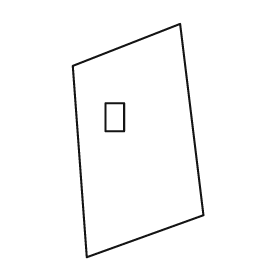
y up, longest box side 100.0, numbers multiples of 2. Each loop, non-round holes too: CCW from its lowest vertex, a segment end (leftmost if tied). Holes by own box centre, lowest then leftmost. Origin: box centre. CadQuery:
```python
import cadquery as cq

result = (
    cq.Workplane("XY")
    .moveTo(-22.0, -50.0)
    .lineTo(28.0, -32.0)
    .lineTo(18.0, 50.0)
    .lineTo(-28.0, 32.0)
    .close()
    .moveTo(-14.0, 4.0)
    .lineTo(-6.0, 4.0)
    .lineTo(-6.0, 16.0)
    .lineTo(-14.0, 16.0)
    .close()
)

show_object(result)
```